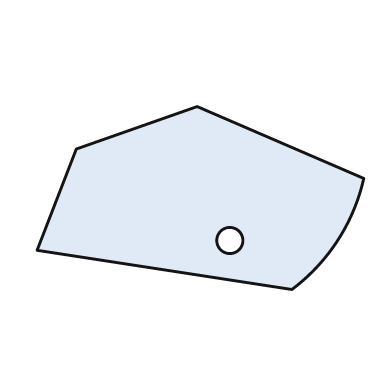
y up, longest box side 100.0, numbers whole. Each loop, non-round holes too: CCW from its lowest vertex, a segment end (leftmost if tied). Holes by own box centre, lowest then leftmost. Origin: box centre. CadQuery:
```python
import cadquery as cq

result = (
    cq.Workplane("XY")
    .moveTo(28.0, -28.0)
    .threePointArc((42.0, -13.0), (50.0, 6.0))
    .lineTo(-1.0, 28.0)
    .lineTo(-38.0, 15.0)
    .lineTo(-50.0, -16.0)
    .close()
    .moveTo(9.0, -13.0)
    .circle(4.0)
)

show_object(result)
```